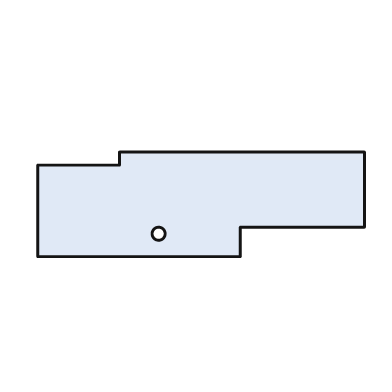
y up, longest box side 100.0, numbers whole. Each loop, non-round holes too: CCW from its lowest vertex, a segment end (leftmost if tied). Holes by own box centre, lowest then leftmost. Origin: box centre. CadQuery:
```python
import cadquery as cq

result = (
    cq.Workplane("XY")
    .moveTo(-50.0, -16.0)
    .lineTo(12.0, -16.0)
    .lineTo(12.0, -7.0)
    .lineTo(50.0, -7.0)
    .lineTo(50.0, 16.0)
    .lineTo(-25.0, 16.0)
    .lineTo(-25.0, 12.0)
    .lineTo(-50.0, 12.0)
    .close()
    .moveTo(-13.0, -9.0)
    .circle(2.0)
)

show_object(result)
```